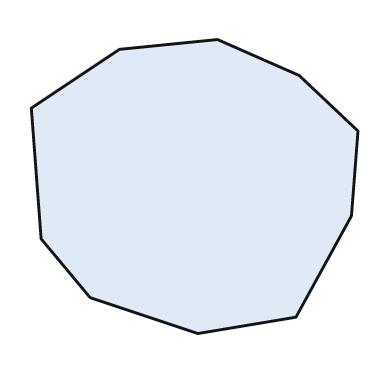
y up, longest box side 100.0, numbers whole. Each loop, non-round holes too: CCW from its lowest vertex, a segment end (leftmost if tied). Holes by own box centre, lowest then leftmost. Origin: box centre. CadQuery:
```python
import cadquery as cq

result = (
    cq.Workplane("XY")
    .moveTo(1.0, -45.0)
    .lineTo(31.0, -40.0)
    .lineTo(48.0, -9.0)
    .lineTo(50.0, 17.0)
    .lineTo(32.0, 34.0)
    .lineTo(7.0, 45.0)
    .lineTo(-23.0, 42.0)
    .lineTo(-50.0, 24.0)
    .lineTo(-47.0, -16.0)
    .lineTo(-32.0, -34.0)
    .close()
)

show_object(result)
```